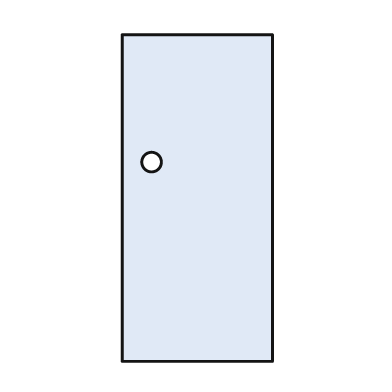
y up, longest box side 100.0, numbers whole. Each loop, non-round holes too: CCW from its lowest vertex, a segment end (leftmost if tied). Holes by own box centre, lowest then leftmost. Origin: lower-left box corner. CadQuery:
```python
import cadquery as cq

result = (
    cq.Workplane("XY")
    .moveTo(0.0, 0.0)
    .lineTo(46.0, 0.0)
    .lineTo(46.0, 100.0)
    .lineTo(0.0, 100.0)
    .close()
    .moveTo(9.0, 61.0)
    .circle(3.0)
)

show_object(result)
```